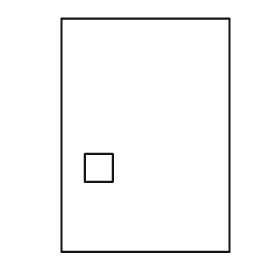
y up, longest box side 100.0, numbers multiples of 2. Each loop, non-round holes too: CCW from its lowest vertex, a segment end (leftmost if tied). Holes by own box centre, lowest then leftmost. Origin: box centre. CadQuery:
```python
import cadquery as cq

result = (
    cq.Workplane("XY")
    .moveTo(-36.0, -50.0)
    .lineTo(36.0, -50.0)
    .lineTo(36.0, 50.0)
    .lineTo(-36.0, 50.0)
    .close()
    .moveTo(-26.0, -20.0)
    .lineTo(-14.0, -20.0)
    .lineTo(-14.0, -8.0)
    .lineTo(-26.0, -8.0)
    .close()
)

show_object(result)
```